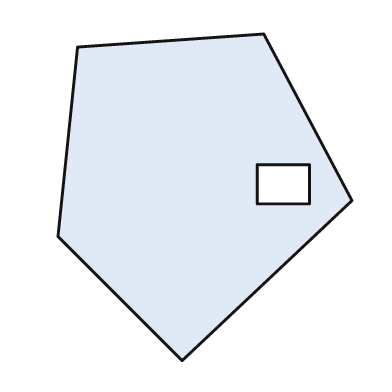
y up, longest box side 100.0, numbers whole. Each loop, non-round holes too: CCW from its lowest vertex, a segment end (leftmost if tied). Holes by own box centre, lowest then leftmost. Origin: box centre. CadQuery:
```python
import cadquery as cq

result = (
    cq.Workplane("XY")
    .moveTo(-7.0, -50.0)
    .lineTo(45.0, -1.0)
    .lineTo(18.0, 50.0)
    .lineTo(-39.0, 46.0)
    .lineTo(-45.0, -12.0)
    .close()
    .moveTo(16.0, -2.0)
    .lineTo(32.0, -2.0)
    .lineTo(32.0, 10.0)
    .lineTo(16.0, 10.0)
    .close()
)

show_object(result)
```